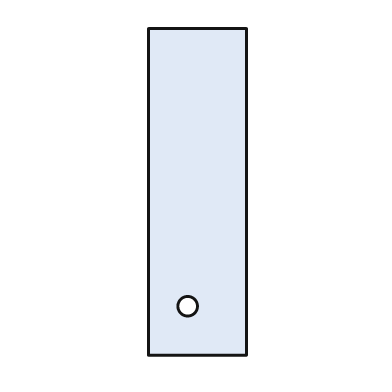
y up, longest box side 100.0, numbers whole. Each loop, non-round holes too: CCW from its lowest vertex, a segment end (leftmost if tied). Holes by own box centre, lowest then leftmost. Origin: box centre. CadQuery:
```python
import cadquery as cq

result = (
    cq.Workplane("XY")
    .moveTo(-15.0, -50.0)
    .lineTo(15.0, -50.0)
    .lineTo(15.0, 50.0)
    .lineTo(-15.0, 50.0)
    .close()
    .moveTo(-3.0, -35.0)
    .circle(3.0)
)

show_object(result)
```